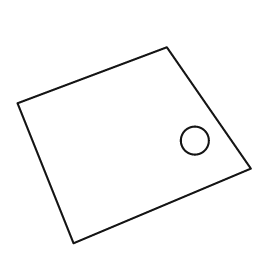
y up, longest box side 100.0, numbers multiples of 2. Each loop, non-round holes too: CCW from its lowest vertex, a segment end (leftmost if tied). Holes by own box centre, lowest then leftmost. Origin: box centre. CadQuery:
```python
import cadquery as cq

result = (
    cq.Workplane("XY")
    .moveTo(-26.0, -42.0)
    .lineTo(50.0, -10.0)
    .lineTo(14.0, 42.0)
    .lineTo(-50.0, 18.0)
    .close()
    .moveTo(26.0, 2.0)
    .circle(6.0)
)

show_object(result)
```